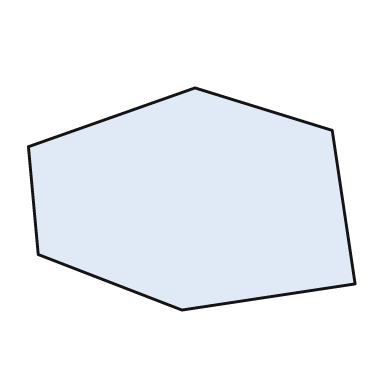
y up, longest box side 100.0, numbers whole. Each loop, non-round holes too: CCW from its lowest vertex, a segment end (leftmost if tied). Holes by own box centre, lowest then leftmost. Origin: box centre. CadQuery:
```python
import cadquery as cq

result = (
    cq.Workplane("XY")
    .moveTo(-3.0, -34.0)
    .lineTo(50.0, -26.0)
    .lineTo(43.0, 21.0)
    .lineTo(1.0, 34.0)
    .lineTo(-50.0, 16.0)
    .lineTo(-47.0, -17.0)
    .close()
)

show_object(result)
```